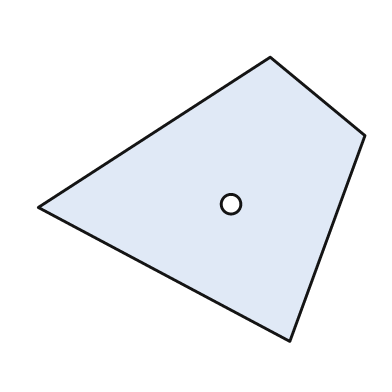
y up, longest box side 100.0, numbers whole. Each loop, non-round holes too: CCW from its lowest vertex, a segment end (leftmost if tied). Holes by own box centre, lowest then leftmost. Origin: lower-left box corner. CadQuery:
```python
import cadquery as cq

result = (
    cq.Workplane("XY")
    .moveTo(77.0, 0.0)
    .lineTo(100.0, 63.0)
    .lineTo(71.0, 87.0)
    .lineTo(0.0, 41.0)
    .close()
    .moveTo(59.0, 42.0)
    .circle(3.0)
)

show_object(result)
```